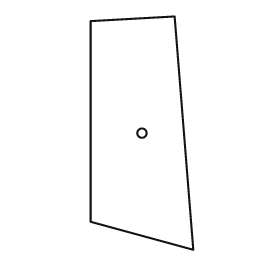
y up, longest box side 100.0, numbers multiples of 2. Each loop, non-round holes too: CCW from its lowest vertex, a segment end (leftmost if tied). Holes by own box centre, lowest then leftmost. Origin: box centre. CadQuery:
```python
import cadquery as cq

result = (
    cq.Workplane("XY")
    .moveTo(22.0, -50.0)
    .lineTo(14.0, 50.0)
    .lineTo(-22.0, 48.0)
    .lineTo(-22.0, -38.0)
    .close()
    .moveTo(0.0, 0.0)
    .circle(2.0)
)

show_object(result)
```